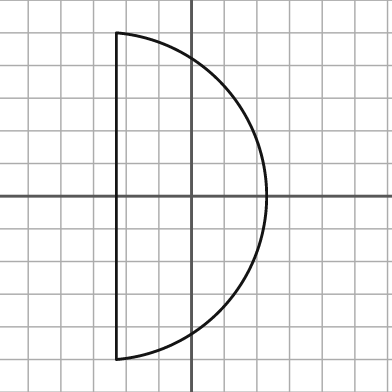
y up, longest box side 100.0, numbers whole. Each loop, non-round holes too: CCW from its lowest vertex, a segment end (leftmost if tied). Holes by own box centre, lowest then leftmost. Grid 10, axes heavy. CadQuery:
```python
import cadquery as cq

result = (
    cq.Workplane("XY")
    .moveTo(-23.0, -50.0)
    .threePointArc((23.0, 0.0), (-23.0, 50.0))
    .close()
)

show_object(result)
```